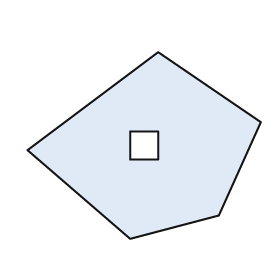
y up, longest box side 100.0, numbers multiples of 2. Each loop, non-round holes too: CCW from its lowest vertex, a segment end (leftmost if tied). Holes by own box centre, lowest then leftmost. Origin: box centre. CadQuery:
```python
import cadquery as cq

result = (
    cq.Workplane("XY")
    .moveTo(-6.0, -40.0)
    .lineTo(32.0, -30.0)
    .lineTo(50.0, 10.0)
    .lineTo(6.0, 40.0)
    .lineTo(-50.0, -2.0)
    .close()
    .moveTo(-6.0, -6.0)
    .lineTo(6.0, -6.0)
    .lineTo(6.0, 6.0)
    .lineTo(-6.0, 6.0)
    .close()
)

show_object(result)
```